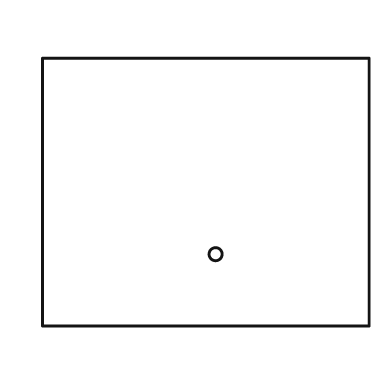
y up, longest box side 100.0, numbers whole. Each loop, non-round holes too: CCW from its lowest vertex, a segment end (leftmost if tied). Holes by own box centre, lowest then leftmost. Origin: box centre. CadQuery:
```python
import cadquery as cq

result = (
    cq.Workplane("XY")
    .moveTo(-50.0, -41.0)
    .lineTo(50.0, -41.0)
    .lineTo(50.0, 41.0)
    .lineTo(-50.0, 41.0)
    .close()
    .moveTo(3.0, -19.0)
    .circle(2.0)
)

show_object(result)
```